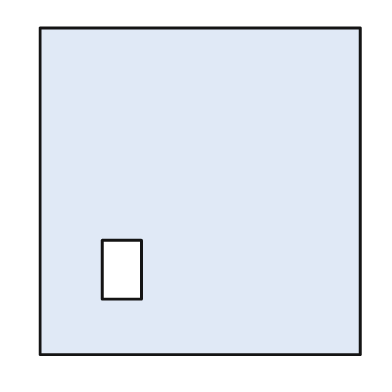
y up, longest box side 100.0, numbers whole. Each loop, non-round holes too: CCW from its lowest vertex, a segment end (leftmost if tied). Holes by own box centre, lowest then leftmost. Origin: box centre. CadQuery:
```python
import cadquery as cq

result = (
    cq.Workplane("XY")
    .moveTo(-49.0, -50.0)
    .lineTo(49.0, -50.0)
    .lineTo(49.0, 50.0)
    .lineTo(-49.0, 50.0)
    .close()
    .moveTo(-30.0, -33.0)
    .lineTo(-18.0, -33.0)
    .lineTo(-18.0, -15.0)
    .lineTo(-30.0, -15.0)
    .close()
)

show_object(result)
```